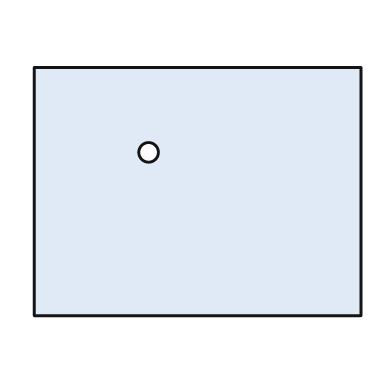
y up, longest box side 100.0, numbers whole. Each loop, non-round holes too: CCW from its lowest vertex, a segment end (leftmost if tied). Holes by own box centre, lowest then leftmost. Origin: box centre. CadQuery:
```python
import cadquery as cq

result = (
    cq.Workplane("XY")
    .moveTo(-50.0, -38.0)
    .lineTo(50.0, -38.0)
    .lineTo(50.0, 38.0)
    .lineTo(-50.0, 38.0)
    .close()
    .moveTo(-15.0, 12.0)
    .circle(3.0)
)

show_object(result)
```